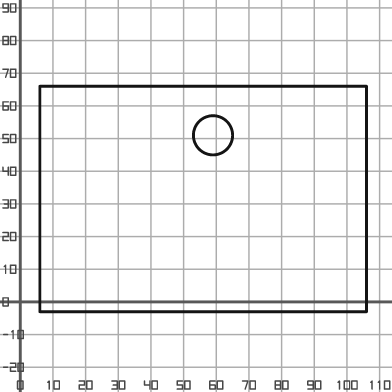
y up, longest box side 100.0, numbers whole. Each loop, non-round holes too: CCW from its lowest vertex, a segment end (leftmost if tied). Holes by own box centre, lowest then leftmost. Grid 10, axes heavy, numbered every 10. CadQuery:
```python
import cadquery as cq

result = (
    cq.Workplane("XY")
    .moveTo(6.0, -3.0)
    .lineTo(106.0, -3.0)
    .lineTo(106.0, 66.0)
    .lineTo(6.0, 66.0)
    .close()
    .moveTo(59.0, 51.0)
    .circle(6.0)
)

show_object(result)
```